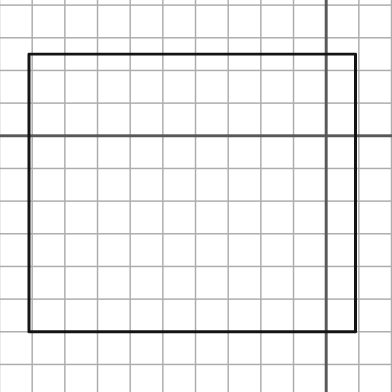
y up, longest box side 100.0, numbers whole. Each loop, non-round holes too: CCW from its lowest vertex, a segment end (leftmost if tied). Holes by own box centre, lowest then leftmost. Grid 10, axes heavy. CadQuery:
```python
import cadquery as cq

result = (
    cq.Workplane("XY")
    .moveTo(-91.0, -60.0)
    .lineTo(9.0, -60.0)
    .lineTo(9.0, 25.0)
    .lineTo(-91.0, 25.0)
    .close()
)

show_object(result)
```